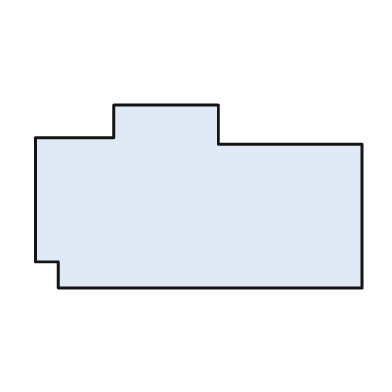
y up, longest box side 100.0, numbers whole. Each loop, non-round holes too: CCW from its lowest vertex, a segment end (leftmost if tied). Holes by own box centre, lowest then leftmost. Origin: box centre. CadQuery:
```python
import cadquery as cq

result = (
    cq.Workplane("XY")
    .moveTo(-43.0, -28.0)
    .lineTo(50.0, -28.0)
    .lineTo(50.0, 16.0)
    .lineTo(6.0, 16.0)
    .lineTo(6.0, 28.0)
    .lineTo(-26.0, 28.0)
    .lineTo(-26.0, 18.0)
    .lineTo(-50.0, 18.0)
    .lineTo(-50.0, -20.0)
    .lineTo(-43.0, -20.0)
    .close()
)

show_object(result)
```